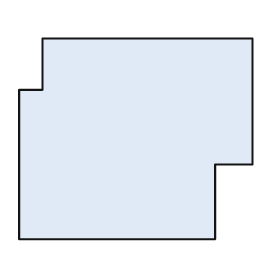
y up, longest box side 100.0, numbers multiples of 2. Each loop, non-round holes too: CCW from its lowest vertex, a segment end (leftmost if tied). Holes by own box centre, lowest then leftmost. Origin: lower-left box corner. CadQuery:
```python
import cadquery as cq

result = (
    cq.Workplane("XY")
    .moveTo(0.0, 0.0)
    .lineTo(84.0, 0.0)
    .lineTo(84.0, 32.0)
    .lineTo(100.0, 32.0)
    .lineTo(100.0, 86.0)
    .lineTo(10.0, 86.0)
    .lineTo(10.0, 64.0)
    .lineTo(0.0, 64.0)
    .close()
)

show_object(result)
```